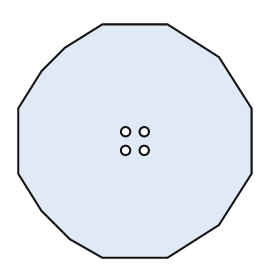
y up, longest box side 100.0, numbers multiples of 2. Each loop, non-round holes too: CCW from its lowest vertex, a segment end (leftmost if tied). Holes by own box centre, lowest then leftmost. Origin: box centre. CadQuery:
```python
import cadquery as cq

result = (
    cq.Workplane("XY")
    .moveTo(-14.0, -50.0)
    .lineTo(14.0, -50.0)
    .lineTo(36.0, -36.0)
    .lineTo(50.0, -14.0)
    .lineTo(50.0, 14.0)
    .lineTo(36.0, 36.0)
    .lineTo(14.0, 50.0)
    .lineTo(-14.0, 50.0)
    .lineTo(-30.0, 40.0)
    .lineTo(-40.0, 30.0)
    .lineTo(-50.0, 14.0)
    .lineTo(-50.0, -14.0)
    .lineTo(-40.0, -30.0)
    .lineTo(-28.0, -42.0)
    .close()
    .moveTo(-4.0, -4.0)
    .circle(2.0)
    .moveTo(4.0, -4.0)
    .circle(2.0)
    .moveTo(-4.0, 4.0)
    .circle(2.0)
    .moveTo(4.0, 4.0)
    .circle(2.0)
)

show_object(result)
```